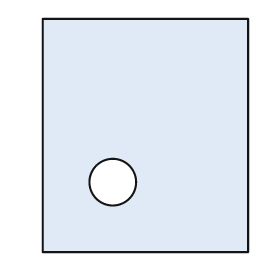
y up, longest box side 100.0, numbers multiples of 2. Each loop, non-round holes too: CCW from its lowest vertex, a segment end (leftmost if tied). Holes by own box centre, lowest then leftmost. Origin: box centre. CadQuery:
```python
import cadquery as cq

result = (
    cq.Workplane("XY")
    .moveTo(-44.0, -50.0)
    .lineTo(44.0, -50.0)
    .lineTo(44.0, 50.0)
    .lineTo(-44.0, 50.0)
    .close()
    .moveTo(-14.0, -20.0)
    .circle(10.0)
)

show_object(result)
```